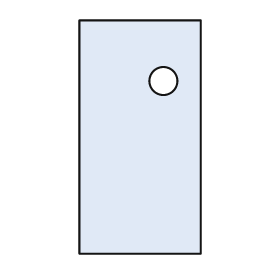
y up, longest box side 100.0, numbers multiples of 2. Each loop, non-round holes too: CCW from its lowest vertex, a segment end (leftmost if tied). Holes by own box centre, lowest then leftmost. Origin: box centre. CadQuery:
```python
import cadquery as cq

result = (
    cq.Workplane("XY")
    .moveTo(-26.0, -50.0)
    .lineTo(26.0, -50.0)
    .lineTo(26.0, 50.0)
    .lineTo(-26.0, 50.0)
    .close()
    .moveTo(10.0, 24.0)
    .circle(6.0)
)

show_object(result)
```